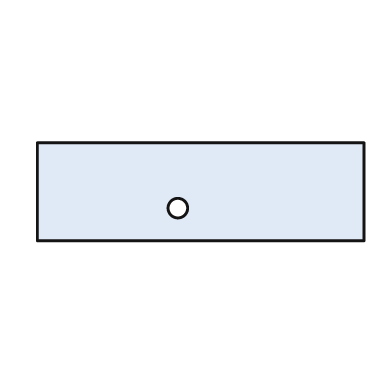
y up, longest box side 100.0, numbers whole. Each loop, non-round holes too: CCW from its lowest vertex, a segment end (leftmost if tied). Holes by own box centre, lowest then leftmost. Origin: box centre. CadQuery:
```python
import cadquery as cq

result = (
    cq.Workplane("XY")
    .moveTo(-50.0, -15.0)
    .lineTo(50.0, -15.0)
    .lineTo(50.0, 15.0)
    .lineTo(-50.0, 15.0)
    .close()
    .moveTo(-7.0, -5.0)
    .circle(3.0)
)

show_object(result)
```